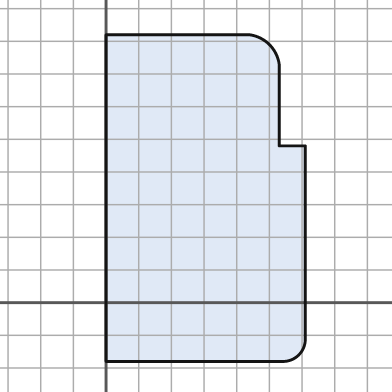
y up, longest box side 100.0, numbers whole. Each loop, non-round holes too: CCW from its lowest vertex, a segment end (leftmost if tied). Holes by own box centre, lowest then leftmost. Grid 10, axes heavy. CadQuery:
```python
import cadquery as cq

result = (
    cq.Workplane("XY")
    .moveTo(0.0, -18.0)
    .lineTo(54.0, -18.0)
    .threePointArc((59.0, -16.0), (61.0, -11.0))
    .lineTo(61.0, 48.0)
    .lineTo(53.0, 48.0)
    .lineTo(53.0, 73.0)
    .threePointArc((50.0, 79.0), (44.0, 82.0))
    .lineTo(0.0, 82.0)
    .close()
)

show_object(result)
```